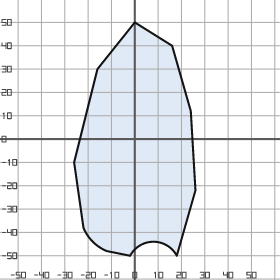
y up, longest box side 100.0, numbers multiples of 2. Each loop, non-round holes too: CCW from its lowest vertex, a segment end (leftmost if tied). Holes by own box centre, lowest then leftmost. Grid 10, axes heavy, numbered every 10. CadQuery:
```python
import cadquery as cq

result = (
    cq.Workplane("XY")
    .moveTo(-2.0, -50.0)
    .threePointArc((8.0, -44.0), (18.0, -50.0))
    .lineTo(26.0, -22.0)
    .lineTo(24.0, 12.0)
    .lineTo(16.0, 40.0)
    .lineTo(0.0, 50.0)
    .lineTo(-16.0, 30.0)
    .lineTo(-26.0, -10.0)
    .lineTo(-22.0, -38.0)
    .threePointArc((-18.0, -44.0), (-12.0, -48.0))
    .close()
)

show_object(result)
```